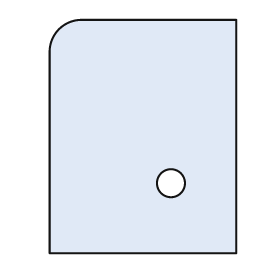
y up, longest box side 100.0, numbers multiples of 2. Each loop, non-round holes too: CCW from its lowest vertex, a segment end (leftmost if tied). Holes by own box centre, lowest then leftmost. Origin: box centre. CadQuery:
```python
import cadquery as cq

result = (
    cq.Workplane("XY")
    .moveTo(-40.0, -50.0)
    .lineTo(40.0, -50.0)
    .lineTo(40.0, 50.0)
    .lineTo(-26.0, 50.0)
    .threePointArc((-36.0, 46.0), (-40.0, 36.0))
    .close()
    .moveTo(12.0, -20.0)
    .circle(6.0)
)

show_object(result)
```